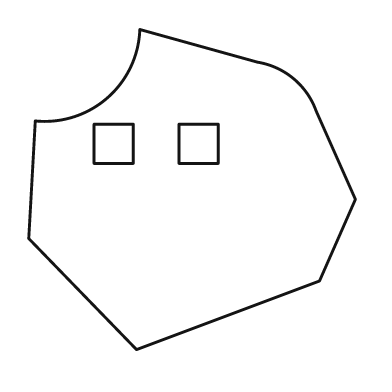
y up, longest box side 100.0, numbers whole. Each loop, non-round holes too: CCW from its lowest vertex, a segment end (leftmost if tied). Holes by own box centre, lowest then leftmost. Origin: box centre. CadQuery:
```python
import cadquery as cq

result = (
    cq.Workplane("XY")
    .moveTo(-17.0, -49.0)
    .lineTo(39.0, -28.0)
    .lineTo(50.0, -3.0)
    .lineTo(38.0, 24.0)
    .threePointArc((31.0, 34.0), (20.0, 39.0))
    .lineTo(-16.0, 49.0)
    .threePointArc((-26.0, 28.0), (-48.0, 21.0))
    .lineTo(-50.0, -15.0)
    .close()
    .moveTo(-30.0, 8.0)
    .lineTo(-18.0, 8.0)
    .lineTo(-18.0, 20.0)
    .lineTo(-30.0, 20.0)
    .close()
    .moveTo(-4.0, 8.0)
    .lineTo(8.0, 8.0)
    .lineTo(8.0, 20.0)
    .lineTo(-4.0, 20.0)
    .close()
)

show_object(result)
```